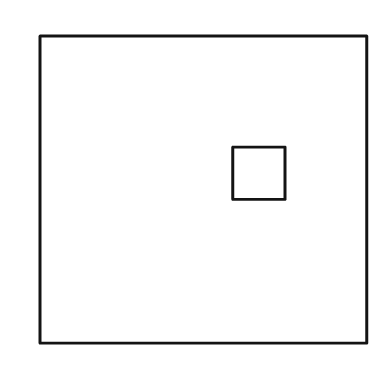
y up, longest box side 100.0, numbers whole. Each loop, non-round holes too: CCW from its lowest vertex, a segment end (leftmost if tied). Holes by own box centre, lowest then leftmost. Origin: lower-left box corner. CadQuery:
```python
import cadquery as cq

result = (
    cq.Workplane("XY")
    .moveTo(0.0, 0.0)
    .lineTo(100.0, 0.0)
    .lineTo(100.0, 94.0)
    .lineTo(0.0, 94.0)
    .close()
    .moveTo(59.0, 44.0)
    .lineTo(75.0, 44.0)
    .lineTo(75.0, 60.0)
    .lineTo(59.0, 60.0)
    .close()
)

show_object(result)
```